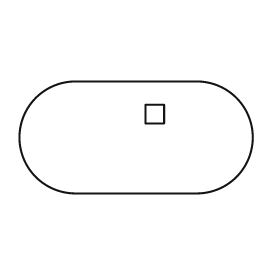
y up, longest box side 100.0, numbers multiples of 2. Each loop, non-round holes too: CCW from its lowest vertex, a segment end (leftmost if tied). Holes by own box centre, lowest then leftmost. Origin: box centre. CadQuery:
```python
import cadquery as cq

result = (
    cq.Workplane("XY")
    .moveTo(-26.0, -24.0)
    .lineTo(26.0, -24.0)
    .threePointArc((50.0, 0.0), (26.0, 24.0))
    .lineTo(-26.0, 24.0)
    .threePointArc((-50.0, 0.0), (-26.0, -24.0))
    .close()
    .moveTo(4.0, 6.0)
    .lineTo(12.0, 6.0)
    .lineTo(12.0, 14.0)
    .lineTo(4.0, 14.0)
    .close()
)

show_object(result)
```